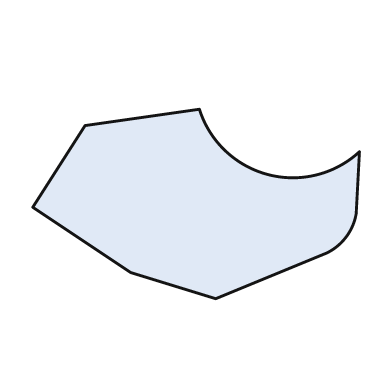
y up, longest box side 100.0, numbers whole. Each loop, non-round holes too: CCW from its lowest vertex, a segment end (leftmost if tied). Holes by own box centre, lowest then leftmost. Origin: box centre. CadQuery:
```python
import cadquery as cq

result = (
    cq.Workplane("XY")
    .moveTo(6.0, -29.0)
    .lineTo(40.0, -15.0)
    .threePointArc((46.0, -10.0), (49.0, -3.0))
    .lineTo(50.0, 16.0)
    .threePointArc((22.0, 9.0), (1.0, 29.0))
    .lineTo(-34.0, 24.0)
    .lineTo(-50.0, -1.0)
    .lineTo(-20.0, -21.0)
    .close()
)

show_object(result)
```